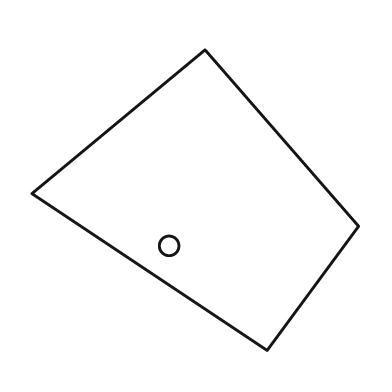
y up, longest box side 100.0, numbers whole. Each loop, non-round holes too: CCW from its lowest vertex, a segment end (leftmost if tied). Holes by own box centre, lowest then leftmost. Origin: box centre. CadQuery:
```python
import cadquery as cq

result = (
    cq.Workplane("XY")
    .moveTo(22.0, -46.0)
    .lineTo(50.0, -8.0)
    .lineTo(3.0, 46.0)
    .lineTo(-50.0, 2.0)
    .close()
    .moveTo(-8.0, -14.0)
    .circle(3.0)
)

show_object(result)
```